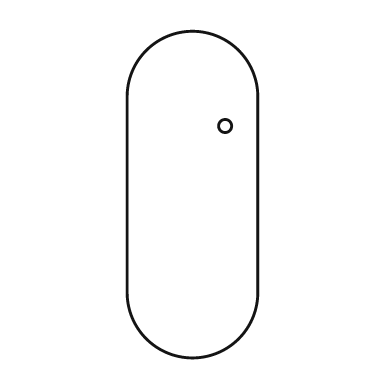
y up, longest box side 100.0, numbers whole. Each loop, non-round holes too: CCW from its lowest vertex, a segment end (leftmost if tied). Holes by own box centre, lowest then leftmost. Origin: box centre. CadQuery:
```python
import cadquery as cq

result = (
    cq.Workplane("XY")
    .moveTo(-20.0, -30.0)
    .threePointArc((0.0, -50.0), (20.0, -30.0))
    .lineTo(20.0, 30.0)
    .threePointArc((0.0, 50.0), (-20.0, 30.0))
    .close()
    .moveTo(10.0, 21.0)
    .circle(2.0)
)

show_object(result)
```